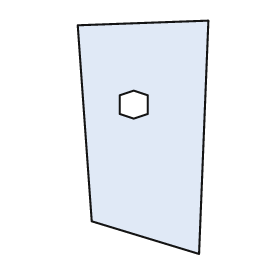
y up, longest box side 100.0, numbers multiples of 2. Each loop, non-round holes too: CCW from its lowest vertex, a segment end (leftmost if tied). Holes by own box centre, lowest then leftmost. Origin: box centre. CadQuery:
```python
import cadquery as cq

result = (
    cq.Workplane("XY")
    .moveTo(24.0, -50.0)
    .lineTo(28.0, 50.0)
    .lineTo(-28.0, 48.0)
    .lineTo(-22.0, -36.0)
    .close()
    .moveTo(-4.0, 8.0)
    .lineTo(2.0, 10.0)
    .lineTo(2.0, 18.0)
    .lineTo(-4.0, 20.0)
    .lineTo(-10.0, 18.0)
    .lineTo(-10.0, 10.0)
    .close()
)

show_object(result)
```